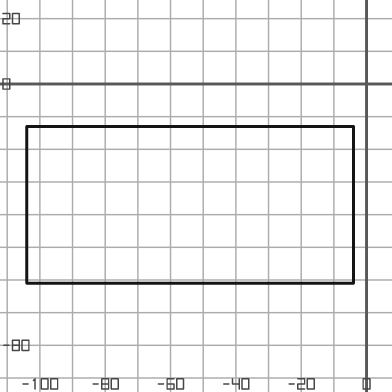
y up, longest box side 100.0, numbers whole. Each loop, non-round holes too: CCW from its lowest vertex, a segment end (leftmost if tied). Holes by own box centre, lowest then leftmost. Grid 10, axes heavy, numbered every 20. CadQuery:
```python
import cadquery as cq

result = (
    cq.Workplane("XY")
    .moveTo(-104.0, -61.0)
    .lineTo(-4.0, -61.0)
    .lineTo(-4.0, -13.0)
    .lineTo(-104.0, -13.0)
    .close()
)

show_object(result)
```